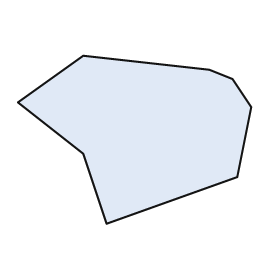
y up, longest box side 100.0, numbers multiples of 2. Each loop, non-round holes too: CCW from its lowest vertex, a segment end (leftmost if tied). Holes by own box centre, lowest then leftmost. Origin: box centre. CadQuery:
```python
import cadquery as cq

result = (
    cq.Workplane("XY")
    .moveTo(-12.0, -36.0)
    .lineTo(44.0, -16.0)
    .lineTo(50.0, 14.0)
    .lineTo(42.0, 26.0)
    .lineTo(32.0, 30.0)
    .lineTo(-22.0, 36.0)
    .lineTo(-50.0, 16.0)
    .lineTo(-22.0, -6.0)
    .close()
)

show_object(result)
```